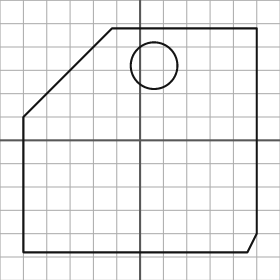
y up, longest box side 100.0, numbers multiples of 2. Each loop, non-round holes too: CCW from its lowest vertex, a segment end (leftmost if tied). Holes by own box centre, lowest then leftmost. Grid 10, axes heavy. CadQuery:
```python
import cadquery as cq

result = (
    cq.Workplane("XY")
    .moveTo(-50.0, -48.0)
    .lineTo(46.0, -48.0)
    .lineTo(50.0, -40.0)
    .lineTo(50.0, 48.0)
    .lineTo(-12.0, 48.0)
    .lineTo(-50.0, 10.0)
    .close()
    .moveTo(6.0, 32.0)
    .circle(10.0)
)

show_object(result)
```